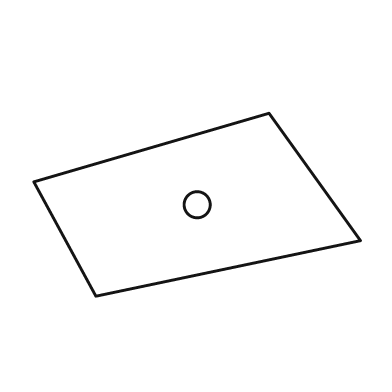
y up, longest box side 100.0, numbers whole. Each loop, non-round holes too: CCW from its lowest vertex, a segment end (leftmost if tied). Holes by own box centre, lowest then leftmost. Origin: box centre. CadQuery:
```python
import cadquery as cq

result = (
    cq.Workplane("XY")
    .moveTo(-31.0, -28.0)
    .lineTo(50.0, -11.0)
    .lineTo(22.0, 28.0)
    .lineTo(-50.0, 7.0)
    .close()
    .moveTo(0.0, 0.0)
    .circle(4.0)
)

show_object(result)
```